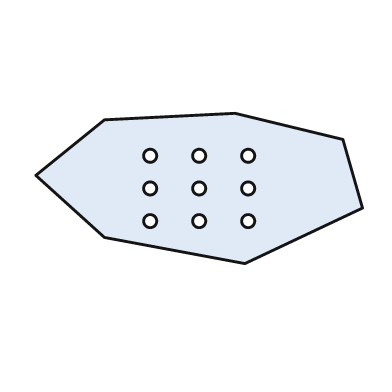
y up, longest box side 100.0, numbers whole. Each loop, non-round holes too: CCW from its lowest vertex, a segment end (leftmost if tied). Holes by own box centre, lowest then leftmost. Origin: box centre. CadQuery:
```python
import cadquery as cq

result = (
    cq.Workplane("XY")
    .moveTo(14.0, -23.0)
    .lineTo(50.0, -6.0)
    .lineTo(44.0, 15.0)
    .lineTo(11.0, 23.0)
    .lineTo(-29.0, 21.0)
    .lineTo(-50.0, 4.0)
    .lineTo(-29.0, -15.0)
    .close()
    .moveTo(-15.0, -10.0)
    .circle(2.0)
    .moveTo(0.0, -10.0)
    .circle(2.0)
    .moveTo(15.0, -10.0)
    .circle(2.0)
    .moveTo(-15.0, 0.0)
    .circle(2.0)
    .moveTo(0.0, 0.0)
    .circle(2.0)
    .moveTo(15.0, 0.0)
    .circle(2.0)
    .moveTo(-15.0, 10.0)
    .circle(2.0)
    .moveTo(0.0, 10.0)
    .circle(2.0)
    .moveTo(15.0, 10.0)
    .circle(2.0)
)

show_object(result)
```